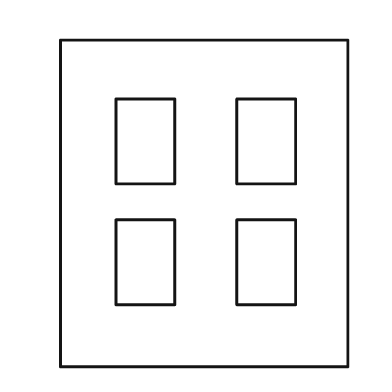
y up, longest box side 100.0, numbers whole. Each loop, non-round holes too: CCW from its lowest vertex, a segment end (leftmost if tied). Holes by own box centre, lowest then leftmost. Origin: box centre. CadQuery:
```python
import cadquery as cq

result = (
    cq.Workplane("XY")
    .moveTo(-44.0, -50.0)
    .lineTo(44.0, -50.0)
    .lineTo(44.0, 50.0)
    .lineTo(-44.0, 50.0)
    .close()
    .moveTo(-27.0, -31.0)
    .lineTo(-9.0, -31.0)
    .lineTo(-9.0, -5.0)
    .lineTo(-27.0, -5.0)
    .close()
    .moveTo(10.0, -31.0)
    .lineTo(28.0, -31.0)
    .lineTo(28.0, -5.0)
    .lineTo(10.0, -5.0)
    .close()
    .moveTo(-27.0, 6.0)
    .lineTo(-9.0, 6.0)
    .lineTo(-9.0, 32.0)
    .lineTo(-27.0, 32.0)
    .close()
    .moveTo(10.0, 6.0)
    .lineTo(28.0, 6.0)
    .lineTo(28.0, 32.0)
    .lineTo(10.0, 32.0)
    .close()
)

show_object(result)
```